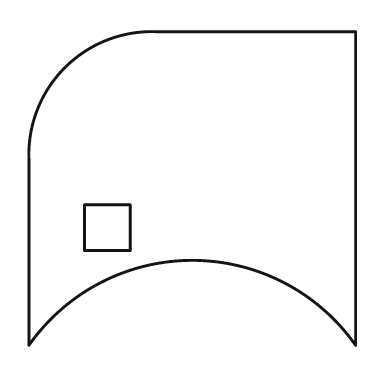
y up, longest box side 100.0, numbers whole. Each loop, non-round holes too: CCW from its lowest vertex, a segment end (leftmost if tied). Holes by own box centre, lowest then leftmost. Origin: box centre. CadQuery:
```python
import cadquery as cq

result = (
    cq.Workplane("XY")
    .moveTo(-50.0, -48.0)
    .threePointArc((0.0, -22.0), (50.0, -48.0))
    .lineTo(50.0, 48.0)
    .lineTo(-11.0, 48.0)
    .threePointArc((-39.0, 37.0), (-50.0, 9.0))
    .close()
    .moveTo(-33.0, -19.0)
    .lineTo(-19.0, -19.0)
    .lineTo(-19.0, -5.0)
    .lineTo(-33.0, -5.0)
    .close()
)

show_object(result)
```